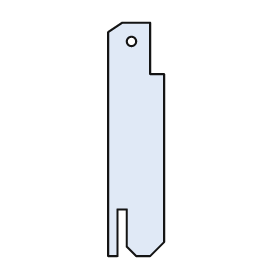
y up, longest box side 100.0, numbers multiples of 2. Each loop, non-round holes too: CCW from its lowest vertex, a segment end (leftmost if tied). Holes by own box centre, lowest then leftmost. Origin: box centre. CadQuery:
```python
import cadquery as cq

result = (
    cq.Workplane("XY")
    .moveTo(-12.0, -50.0)
    .lineTo(-8.0, -50.0)
    .lineTo(-8.0, -30.0)
    .lineTo(-4.0, -30.0)
    .lineTo(-4.0, -46.0)
    .lineTo(0.0, -50.0)
    .lineTo(6.0, -50.0)
    .lineTo(12.0, -44.0)
    .lineTo(12.0, 28.0)
    .lineTo(6.0, 28.0)
    .lineTo(6.0, 50.0)
    .lineTo(-6.0, 50.0)
    .lineTo(-12.0, 46.0)
    .close()
    .moveTo(-2.0, 42.0)
    .circle(2.0)
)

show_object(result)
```